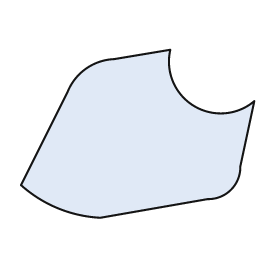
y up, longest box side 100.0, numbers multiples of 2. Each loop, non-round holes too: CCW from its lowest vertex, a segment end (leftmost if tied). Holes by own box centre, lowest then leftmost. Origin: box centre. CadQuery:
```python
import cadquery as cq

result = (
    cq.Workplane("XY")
    .moveTo(-16.0, -36.0)
    .lineTo(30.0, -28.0)
    .threePointArc((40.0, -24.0), (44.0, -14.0))
    .lineTo(50.0, 14.0)
    .threePointArc((24.0, 12.0), (14.0, 36.0))
    .lineTo(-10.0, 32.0)
    .threePointArc((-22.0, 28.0), (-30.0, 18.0))
    .lineTo(-50.0, -22.0)
    .threePointArc((-34.0, -32.0), (-16.0, -36.0))
    .close()
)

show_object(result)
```